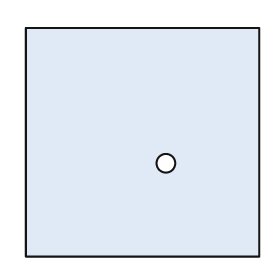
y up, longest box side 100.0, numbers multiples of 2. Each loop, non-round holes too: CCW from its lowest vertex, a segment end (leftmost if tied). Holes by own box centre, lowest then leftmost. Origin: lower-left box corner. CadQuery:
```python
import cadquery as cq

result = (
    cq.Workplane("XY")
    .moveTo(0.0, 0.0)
    .lineTo(100.0, 0.0)
    .lineTo(100.0, 98.0)
    .lineTo(0.0, 98.0)
    .close()
    .moveTo(60.0, 40.0)
    .circle(4.0)
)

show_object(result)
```